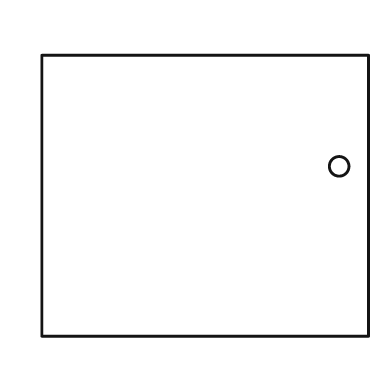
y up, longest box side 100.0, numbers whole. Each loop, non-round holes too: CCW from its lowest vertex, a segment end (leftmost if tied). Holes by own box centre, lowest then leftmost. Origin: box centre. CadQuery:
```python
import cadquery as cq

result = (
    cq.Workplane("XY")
    .moveTo(-50.0, -43.0)
    .lineTo(50.0, -43.0)
    .lineTo(50.0, 43.0)
    .lineTo(-50.0, 43.0)
    .close()
    .moveTo(41.0, 9.0)
    .circle(3.0)
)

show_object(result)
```